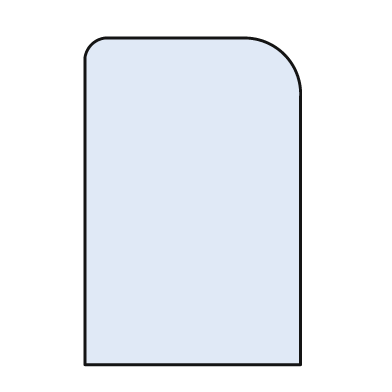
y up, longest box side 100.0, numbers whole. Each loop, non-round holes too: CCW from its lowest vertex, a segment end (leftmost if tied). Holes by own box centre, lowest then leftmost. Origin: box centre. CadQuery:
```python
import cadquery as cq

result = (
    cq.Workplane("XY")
    .moveTo(-33.0, -50.0)
    .lineTo(33.0, -50.0)
    .lineTo(33.0, 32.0)
    .threePointArc((28.0, 45.0), (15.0, 50.0))
    .lineTo(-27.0, 50.0)
    .threePointArc((-31.0, 48.0), (-33.0, 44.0))
    .close()
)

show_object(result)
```